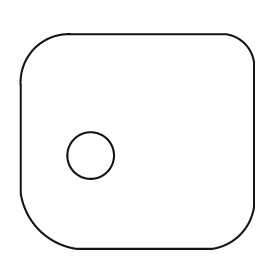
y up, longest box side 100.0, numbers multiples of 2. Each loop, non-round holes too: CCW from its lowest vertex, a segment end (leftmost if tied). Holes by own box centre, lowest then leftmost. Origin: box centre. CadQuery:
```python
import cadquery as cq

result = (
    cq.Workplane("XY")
    .moveTo(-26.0, -46.0)
    .lineTo(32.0, -46.0)
    .threePointArc((44.0, -40.0), (50.0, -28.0))
    .lineTo(50.0, 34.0)
    .threePointArc((46.0, 42.0), (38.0, 46.0))
    .lineTo(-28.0, 46.0)
    .threePointArc((-44.0, 40.0), (-50.0, 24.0))
    .lineTo(-50.0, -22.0)
    .threePointArc((-42.0, -38.0), (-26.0, -46.0))
    .close()
    .moveTo(-20.0, -6.0)
    .circle(10.0)
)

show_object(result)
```